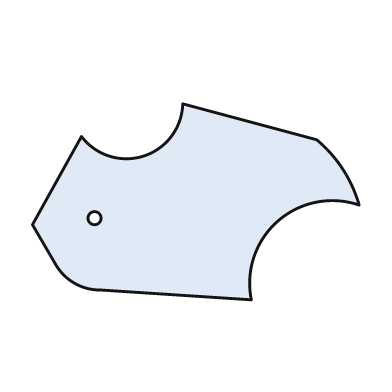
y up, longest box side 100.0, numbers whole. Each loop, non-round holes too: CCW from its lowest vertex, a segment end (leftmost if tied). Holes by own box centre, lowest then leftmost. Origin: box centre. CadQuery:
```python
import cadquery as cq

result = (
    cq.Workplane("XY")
    .moveTo(17.0, -30.0)
    .threePointArc((25.0, -6.0), (50.0, -1.0))
    .threePointArc((45.0, 10.0), (37.0, 19.0))
    .lineTo(-4.0, 30.0)
    .threePointArc((-16.0, 14.0), (-35.0, 20.0))
    .lineTo(-50.0, -7.0)
    .lineTo(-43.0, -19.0)
    .threePointArc((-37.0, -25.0), (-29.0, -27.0))
    .close()
    .moveTo(-31.0, -5.0)
    .circle(2.0)
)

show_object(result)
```